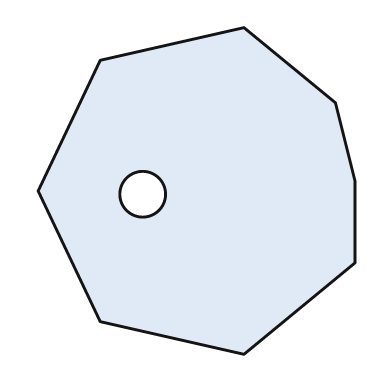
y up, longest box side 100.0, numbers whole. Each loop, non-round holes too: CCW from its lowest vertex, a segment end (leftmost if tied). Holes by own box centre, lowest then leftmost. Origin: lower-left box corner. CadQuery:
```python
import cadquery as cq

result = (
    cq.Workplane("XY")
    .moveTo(63.0, 0.0)
    .lineTo(97.0, 28.0)
    .lineTo(97.0, 53.0)
    .lineTo(91.0, 77.0)
    .lineTo(63.0, 100.0)
    .lineTo(19.0, 90.0)
    .lineTo(0.0, 50.0)
    .lineTo(19.0, 10.0)
    .close()
    .moveTo(32.0, 49.0)
    .circle(7.0)
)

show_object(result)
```